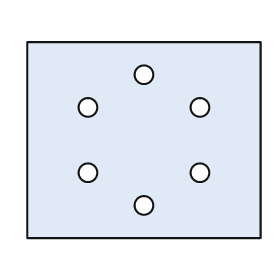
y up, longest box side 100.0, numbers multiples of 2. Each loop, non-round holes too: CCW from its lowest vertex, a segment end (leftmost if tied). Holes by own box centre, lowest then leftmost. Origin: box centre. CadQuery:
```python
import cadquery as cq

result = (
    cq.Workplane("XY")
    .moveTo(-50.0, -42.0)
    .lineTo(50.0, -42.0)
    .lineTo(50.0, 42.0)
    .lineTo(-50.0, 42.0)
    .close()
    .moveTo(0.0, -28.0)
    .circle(4.0)
    .moveTo(-24.0, -14.0)
    .circle(4.0)
    .moveTo(24.0, -14.0)
    .circle(4.0)
    .moveTo(-24.0, 14.0)
    .circle(4.0)
    .moveTo(24.0, 14.0)
    .circle(4.0)
    .moveTo(0.0, 28.0)
    .circle(4.0)
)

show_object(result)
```